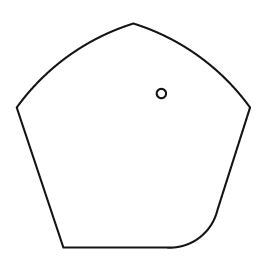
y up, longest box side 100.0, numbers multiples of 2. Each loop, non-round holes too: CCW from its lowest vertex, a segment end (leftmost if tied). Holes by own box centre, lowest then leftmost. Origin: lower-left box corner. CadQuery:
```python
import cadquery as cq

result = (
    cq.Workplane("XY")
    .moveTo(20.0, 0.0)
    .lineTo(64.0, 0.0)
    .threePointArc((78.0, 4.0), (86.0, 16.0))
    .lineTo(100.0, 60.0)
    .threePointArc((78.0, 82.0), (50.0, 96.0))
    .threePointArc((22.0, 82.0), (0.0, 60.0))
    .close()
    .moveTo(62.0, 66.0)
    .circle(2.0)
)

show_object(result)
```